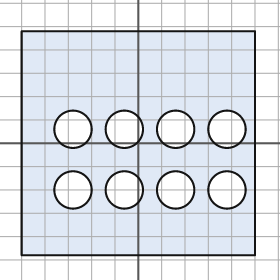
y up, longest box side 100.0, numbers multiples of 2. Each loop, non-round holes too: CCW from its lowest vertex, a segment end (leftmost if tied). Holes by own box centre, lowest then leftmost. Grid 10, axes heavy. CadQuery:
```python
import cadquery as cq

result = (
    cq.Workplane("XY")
    .moveTo(-50.0, -48.0)
    .lineTo(50.0, -48.0)
    .lineTo(50.0, 48.0)
    .lineTo(-50.0, 48.0)
    .close()
    .moveTo(-28.0, -20.0)
    .circle(8.0)
    .moveTo(-6.0, -20.0)
    .circle(8.0)
    .moveTo(16.0, -20.0)
    .circle(8.0)
    .moveTo(38.0, -20.0)
    .circle(8.0)
    .moveTo(-28.0, 6.0)
    .circle(8.0)
    .moveTo(-6.0, 6.0)
    .circle(8.0)
    .moveTo(16.0, 6.0)
    .circle(8.0)
    .moveTo(38.0, 6.0)
    .circle(8.0)
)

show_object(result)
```